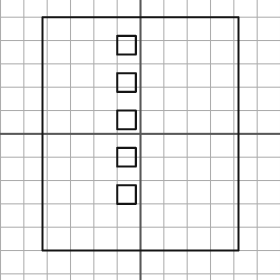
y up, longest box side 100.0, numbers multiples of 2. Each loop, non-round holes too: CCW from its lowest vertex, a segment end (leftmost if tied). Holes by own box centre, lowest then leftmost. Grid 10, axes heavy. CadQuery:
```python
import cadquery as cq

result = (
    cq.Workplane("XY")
    .moveTo(-42.0, -50.0)
    .lineTo(42.0, -50.0)
    .lineTo(42.0, 50.0)
    .lineTo(-42.0, 50.0)
    .close()
    .moveTo(-10.0, -30.0)
    .lineTo(-2.0, -30.0)
    .lineTo(-2.0, -22.0)
    .lineTo(-10.0, -22.0)
    .close()
    .moveTo(-10.0, -14.0)
    .lineTo(-2.0, -14.0)
    .lineTo(-2.0, -6.0)
    .lineTo(-10.0, -6.0)
    .close()
    .moveTo(-10.0, 2.0)
    .lineTo(-2.0, 2.0)
    .lineTo(-2.0, 10.0)
    .lineTo(-10.0, 10.0)
    .close()
    .moveTo(-10.0, 18.0)
    .lineTo(-2.0, 18.0)
    .lineTo(-2.0, 26.0)
    .lineTo(-10.0, 26.0)
    .close()
    .moveTo(-10.0, 34.0)
    .lineTo(-2.0, 34.0)
    .lineTo(-2.0, 42.0)
    .lineTo(-10.0, 42.0)
    .close()
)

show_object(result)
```